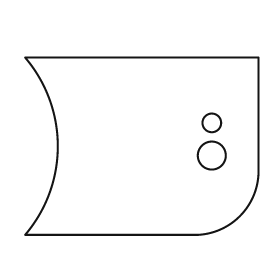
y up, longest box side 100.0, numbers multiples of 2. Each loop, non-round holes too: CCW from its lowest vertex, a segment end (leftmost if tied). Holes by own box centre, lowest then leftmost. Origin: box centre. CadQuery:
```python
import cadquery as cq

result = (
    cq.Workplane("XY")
    .moveTo(-50.0, -38.0)
    .lineTo(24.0, -38.0)
    .threePointArc((42.0, -30.0), (50.0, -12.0))
    .lineTo(50.0, 38.0)
    .lineTo(-50.0, 38.0)
    .threePointArc((-36.0, 0.0), (-50.0, -38.0))
    .close()
    .moveTo(30.0, -4.0)
    .circle(6.0)
    .moveTo(30.0, 10.0)
    .circle(4.0)
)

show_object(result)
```